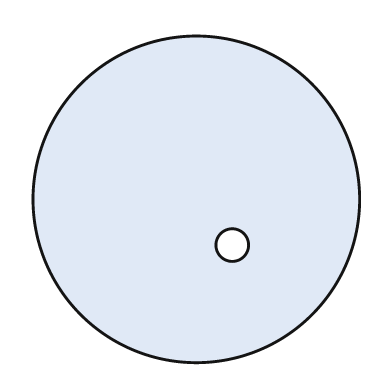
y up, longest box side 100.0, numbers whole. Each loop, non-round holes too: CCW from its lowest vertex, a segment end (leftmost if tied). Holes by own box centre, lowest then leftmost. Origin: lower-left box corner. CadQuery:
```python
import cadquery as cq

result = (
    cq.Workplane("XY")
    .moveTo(50.0, 50.0)
    .circle(50.0)
    .moveTo(61.0, 36.0)
    .circle(5.0)
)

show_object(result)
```